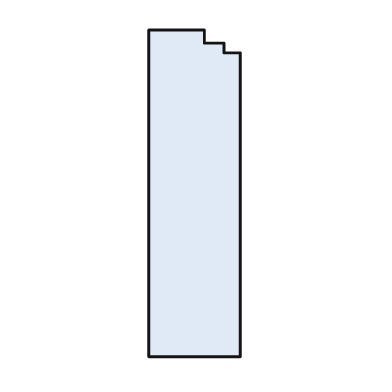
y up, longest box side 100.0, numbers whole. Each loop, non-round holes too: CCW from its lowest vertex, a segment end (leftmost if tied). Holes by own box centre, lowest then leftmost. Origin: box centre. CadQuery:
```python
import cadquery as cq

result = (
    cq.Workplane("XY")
    .moveTo(-14.0, -50.0)
    .lineTo(14.0, -50.0)
    .lineTo(14.0, 43.0)
    .lineTo(9.0, 43.0)
    .lineTo(9.0, 46.0)
    .lineTo(3.0, 46.0)
    .lineTo(3.0, 50.0)
    .lineTo(-14.0, 50.0)
    .close()
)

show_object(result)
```